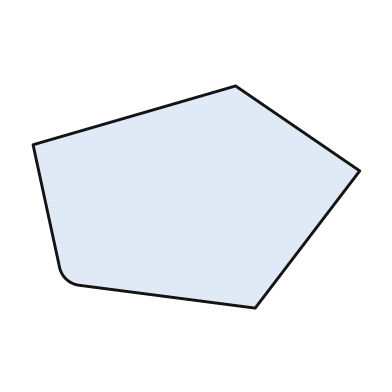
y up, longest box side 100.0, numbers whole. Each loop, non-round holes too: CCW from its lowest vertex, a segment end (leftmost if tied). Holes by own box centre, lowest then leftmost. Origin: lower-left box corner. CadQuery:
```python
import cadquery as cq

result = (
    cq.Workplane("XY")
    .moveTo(68.0, 0.0)
    .lineTo(100.0, 42.0)
    .lineTo(62.0, 68.0)
    .lineTo(0.0, 50.0)
    .lineTo(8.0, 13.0)
    .threePointArc((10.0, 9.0), (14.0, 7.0))
    .close()
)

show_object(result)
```